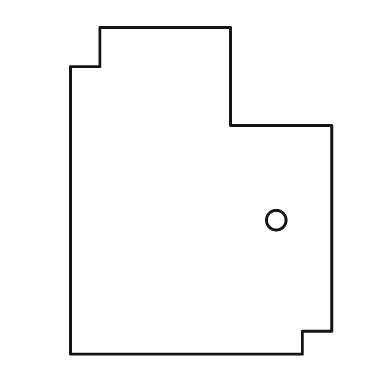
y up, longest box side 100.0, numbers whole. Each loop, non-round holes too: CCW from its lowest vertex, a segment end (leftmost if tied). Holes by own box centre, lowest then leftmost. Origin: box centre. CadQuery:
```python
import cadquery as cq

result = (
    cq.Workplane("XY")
    .moveTo(-40.0, -50.0)
    .lineTo(31.0, -50.0)
    .lineTo(31.0, -43.0)
    .lineTo(40.0, -43.0)
    .lineTo(40.0, 20.0)
    .lineTo(9.0, 20.0)
    .lineTo(9.0, 50.0)
    .lineTo(-31.0, 50.0)
    .lineTo(-31.0, 38.0)
    .lineTo(-40.0, 38.0)
    .close()
    .moveTo(23.0, -9.0)
    .circle(3.0)
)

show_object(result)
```